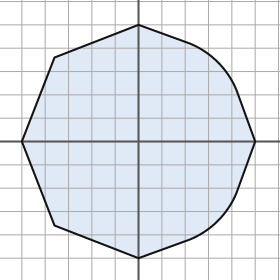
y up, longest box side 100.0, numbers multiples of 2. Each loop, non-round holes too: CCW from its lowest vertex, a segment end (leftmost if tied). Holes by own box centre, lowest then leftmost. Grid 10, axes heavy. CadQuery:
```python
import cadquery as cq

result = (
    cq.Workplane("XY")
    .moveTo(0.0, -50.0)
    .lineTo(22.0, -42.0)
    .threePointArc((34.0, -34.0), (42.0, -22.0))
    .lineTo(50.0, 0.0)
    .lineTo(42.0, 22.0)
    .threePointArc((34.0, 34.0), (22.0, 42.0))
    .lineTo(0.0, 50.0)
    .lineTo(-36.0, 36.0)
    .lineTo(-50.0, 0.0)
    .lineTo(-36.0, -36.0)
    .close()
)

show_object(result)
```